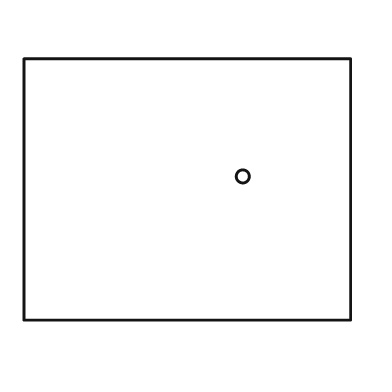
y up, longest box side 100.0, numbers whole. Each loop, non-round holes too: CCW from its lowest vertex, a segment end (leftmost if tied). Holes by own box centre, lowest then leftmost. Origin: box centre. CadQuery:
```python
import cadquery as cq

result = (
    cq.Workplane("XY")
    .moveTo(-50.0, -40.0)
    .lineTo(50.0, -40.0)
    .lineTo(50.0, 40.0)
    .lineTo(-50.0, 40.0)
    .close()
    .moveTo(17.0, 4.0)
    .circle(2.0)
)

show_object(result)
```